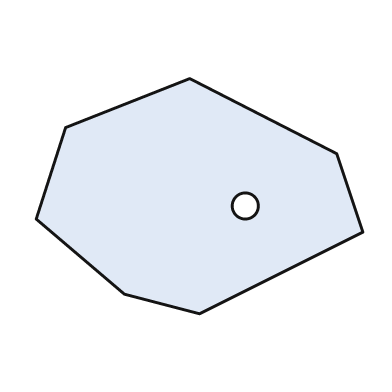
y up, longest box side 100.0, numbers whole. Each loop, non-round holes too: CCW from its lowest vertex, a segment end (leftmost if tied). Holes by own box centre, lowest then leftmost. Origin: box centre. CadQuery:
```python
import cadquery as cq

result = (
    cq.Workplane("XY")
    .moveTo(0.0, -36.0)
    .lineTo(50.0, -11.0)
    .lineTo(42.0, 13.0)
    .lineTo(-3.0, 36.0)
    .lineTo(-41.0, 21.0)
    .lineTo(-50.0, -7.0)
    .lineTo(-23.0, -30.0)
    .close()
    .moveTo(14.0, -3.0)
    .circle(4.0)
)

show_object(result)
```